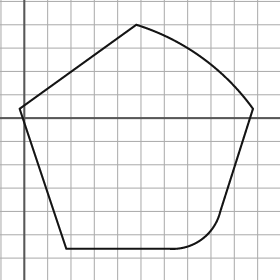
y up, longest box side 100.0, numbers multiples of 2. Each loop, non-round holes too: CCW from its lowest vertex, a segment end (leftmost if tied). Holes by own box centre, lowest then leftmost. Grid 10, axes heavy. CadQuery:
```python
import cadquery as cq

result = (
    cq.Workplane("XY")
    .moveTo(18.0, -56.0)
    .lineTo(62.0, -56.0)
    .threePointArc((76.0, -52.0), (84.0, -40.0))
    .lineTo(98.0, 4.0)
    .threePointArc((76.0, 26.0), (48.0, 40.0))
    .lineTo(-2.0, 4.0)
    .close()
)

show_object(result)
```